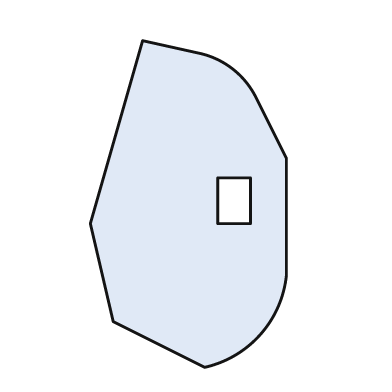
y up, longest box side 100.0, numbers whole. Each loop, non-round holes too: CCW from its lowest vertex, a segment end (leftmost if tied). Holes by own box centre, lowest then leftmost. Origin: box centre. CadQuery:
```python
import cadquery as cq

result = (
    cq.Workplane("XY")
    .moveTo(5.0, -50.0)
    .threePointArc((22.0, -40.0), (30.0, -22.0))
    .lineTo(30.0, 14.0)
    .lineTo(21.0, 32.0)
    .threePointArc((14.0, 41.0), (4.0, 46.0))
    .lineTo(-14.0, 50.0)
    .lineTo(-30.0, -6.0)
    .lineTo(-23.0, -36.0)
    .close()
    .moveTo(9.0, -6.0)
    .lineTo(19.0, -6.0)
    .lineTo(19.0, 8.0)
    .lineTo(9.0, 8.0)
    .close()
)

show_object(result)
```